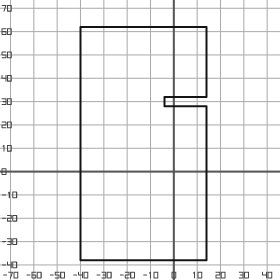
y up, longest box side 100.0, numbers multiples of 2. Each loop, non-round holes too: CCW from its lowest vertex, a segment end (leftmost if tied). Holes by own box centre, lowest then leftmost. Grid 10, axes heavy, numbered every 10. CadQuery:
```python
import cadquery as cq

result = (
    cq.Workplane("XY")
    .moveTo(-40.0, -38.0)
    .lineTo(14.0, -38.0)
    .lineTo(14.0, 28.0)
    .lineTo(-4.0, 28.0)
    .lineTo(-4.0, 32.0)
    .lineTo(14.0, 32.0)
    .lineTo(14.0, 62.0)
    .lineTo(-40.0, 62.0)
    .close()
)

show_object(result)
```